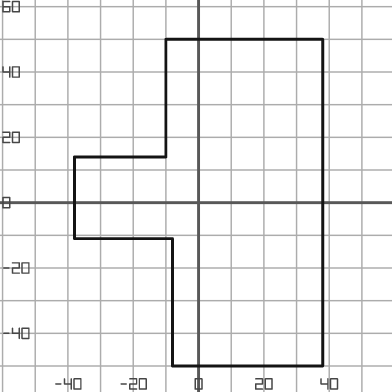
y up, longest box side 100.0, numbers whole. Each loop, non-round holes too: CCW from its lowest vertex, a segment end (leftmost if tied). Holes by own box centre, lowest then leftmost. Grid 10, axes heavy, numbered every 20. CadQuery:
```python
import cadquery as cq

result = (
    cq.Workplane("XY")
    .moveTo(-8.0, -50.0)
    .lineTo(38.0, -50.0)
    .lineTo(38.0, 50.0)
    .lineTo(-10.0, 50.0)
    .lineTo(-10.0, 14.0)
    .lineTo(-38.0, 14.0)
    .lineTo(-38.0, -11.0)
    .lineTo(-8.0, -11.0)
    .close()
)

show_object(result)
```